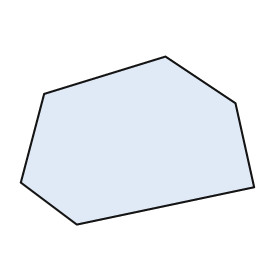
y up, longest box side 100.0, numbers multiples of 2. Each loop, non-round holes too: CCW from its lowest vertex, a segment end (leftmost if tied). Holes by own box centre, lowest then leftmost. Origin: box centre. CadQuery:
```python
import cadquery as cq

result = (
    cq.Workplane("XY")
    .moveTo(-26.0, -36.0)
    .lineTo(50.0, -20.0)
    .lineTo(42.0, 16.0)
    .lineTo(12.0, 36.0)
    .lineTo(-40.0, 20.0)
    .lineTo(-50.0, -18.0)
    .close()
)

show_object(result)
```